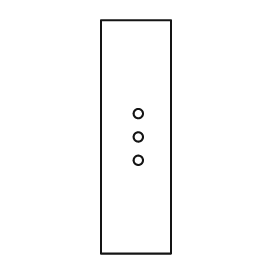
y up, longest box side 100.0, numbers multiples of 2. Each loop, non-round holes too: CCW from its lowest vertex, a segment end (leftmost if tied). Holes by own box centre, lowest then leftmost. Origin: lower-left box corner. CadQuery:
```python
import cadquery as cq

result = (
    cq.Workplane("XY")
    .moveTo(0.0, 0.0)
    .lineTo(30.0, 0.0)
    .lineTo(30.0, 100.0)
    .lineTo(0.0, 100.0)
    .close()
    .moveTo(16.0, 40.0)
    .circle(2.0)
    .moveTo(16.0, 50.0)
    .circle(2.0)
    .moveTo(16.0, 60.0)
    .circle(2.0)
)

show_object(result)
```